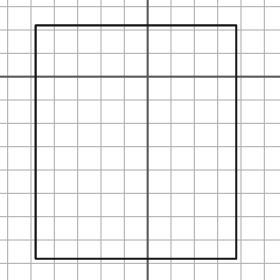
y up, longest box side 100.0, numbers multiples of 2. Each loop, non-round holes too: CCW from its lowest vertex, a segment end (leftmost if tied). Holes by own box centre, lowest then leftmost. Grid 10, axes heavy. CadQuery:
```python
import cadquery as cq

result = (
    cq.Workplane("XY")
    .moveTo(-48.0, -78.0)
    .lineTo(38.0, -78.0)
    .lineTo(38.0, 22.0)
    .lineTo(-48.0, 22.0)
    .close()
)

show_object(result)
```